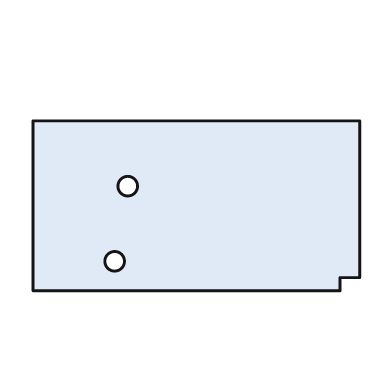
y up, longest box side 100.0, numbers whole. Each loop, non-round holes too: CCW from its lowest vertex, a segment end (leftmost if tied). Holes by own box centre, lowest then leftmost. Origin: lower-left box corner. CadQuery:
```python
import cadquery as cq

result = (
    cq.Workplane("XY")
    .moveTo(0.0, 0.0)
    .lineTo(94.0, 0.0)
    .lineTo(94.0, 4.0)
    .lineTo(100.0, 4.0)
    .lineTo(100.0, 52.0)
    .lineTo(0.0, 52.0)
    .close()
    .moveTo(25.0, 9.0)
    .circle(3.0)
    .moveTo(29.0, 32.0)
    .circle(3.0)
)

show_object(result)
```